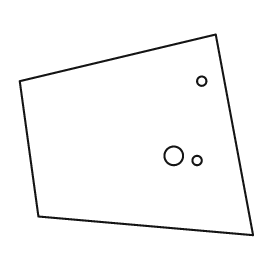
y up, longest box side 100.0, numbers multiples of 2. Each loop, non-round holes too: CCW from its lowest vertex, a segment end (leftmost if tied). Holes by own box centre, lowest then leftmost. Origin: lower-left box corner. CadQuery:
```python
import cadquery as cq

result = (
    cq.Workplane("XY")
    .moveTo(100.0, 0.0)
    .lineTo(84.0, 86.0)
    .lineTo(0.0, 66.0)
    .lineTo(8.0, 8.0)
    .close()
    .moveTo(76.0, 32.0)
    .circle(2.0)
    .moveTo(66.0, 34.0)
    .circle(4.0)
    .moveTo(78.0, 66.0)
    .circle(2.0)
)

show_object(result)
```